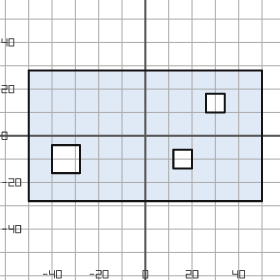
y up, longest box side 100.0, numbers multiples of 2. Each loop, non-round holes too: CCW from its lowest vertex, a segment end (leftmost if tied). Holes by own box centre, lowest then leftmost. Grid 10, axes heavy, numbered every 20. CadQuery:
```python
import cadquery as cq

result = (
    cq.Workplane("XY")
    .moveTo(-50.0, -28.0)
    .lineTo(50.0, -28.0)
    .lineTo(50.0, 28.0)
    .lineTo(-50.0, 28.0)
    .close()
    .moveTo(-40.0, -16.0)
    .lineTo(-28.0, -16.0)
    .lineTo(-28.0, -4.0)
    .lineTo(-40.0, -4.0)
    .close()
    .moveTo(12.0, -14.0)
    .lineTo(20.0, -14.0)
    .lineTo(20.0, -6.0)
    .lineTo(12.0, -6.0)
    .close()
    .moveTo(26.0, 10.0)
    .lineTo(34.0, 10.0)
    .lineTo(34.0, 18.0)
    .lineTo(26.0, 18.0)
    .close()
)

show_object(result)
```